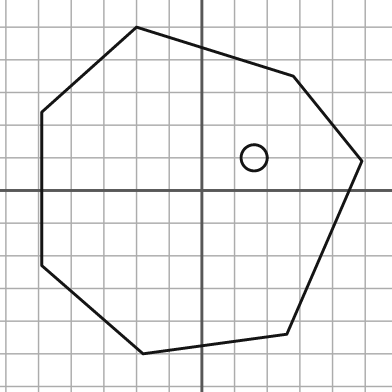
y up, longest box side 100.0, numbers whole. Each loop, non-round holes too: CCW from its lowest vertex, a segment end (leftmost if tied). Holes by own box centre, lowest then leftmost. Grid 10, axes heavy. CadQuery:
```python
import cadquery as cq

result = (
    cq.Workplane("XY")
    .moveTo(-18.0, -50.0)
    .lineTo(26.0, -44.0)
    .lineTo(49.0, 9.0)
    .lineTo(28.0, 35.0)
    .lineTo(-20.0, 50.0)
    .lineTo(-49.0, 24.0)
    .lineTo(-49.0, -23.0)
    .close()
    .moveTo(16.0, 10.0)
    .circle(4.0)
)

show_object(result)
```